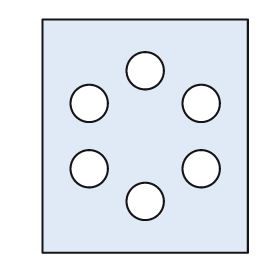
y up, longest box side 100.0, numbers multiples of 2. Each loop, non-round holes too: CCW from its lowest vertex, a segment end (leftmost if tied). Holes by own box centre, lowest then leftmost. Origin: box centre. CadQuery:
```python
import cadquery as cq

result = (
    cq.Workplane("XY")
    .moveTo(-44.0, -50.0)
    .lineTo(44.0, -50.0)
    .lineTo(44.0, 50.0)
    .lineTo(-44.0, 50.0)
    .close()
    .moveTo(0.0, -28.0)
    .circle(8.0)
    .moveTo(-24.0, -14.0)
    .circle(8.0)
    .moveTo(24.0, -14.0)
    .circle(8.0)
    .moveTo(-24.0, 14.0)
    .circle(8.0)
    .moveTo(24.0, 14.0)
    .circle(8.0)
    .moveTo(0.0, 28.0)
    .circle(8.0)
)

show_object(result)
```